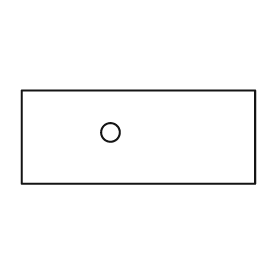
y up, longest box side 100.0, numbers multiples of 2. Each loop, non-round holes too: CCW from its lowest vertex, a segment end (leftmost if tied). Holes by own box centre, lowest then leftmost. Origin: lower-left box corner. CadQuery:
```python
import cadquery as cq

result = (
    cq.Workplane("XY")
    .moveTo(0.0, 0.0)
    .lineTo(100.0, 0.0)
    .lineTo(100.0, 40.0)
    .lineTo(0.0, 40.0)
    .close()
    .moveTo(38.0, 22.0)
    .circle(4.0)
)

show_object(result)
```